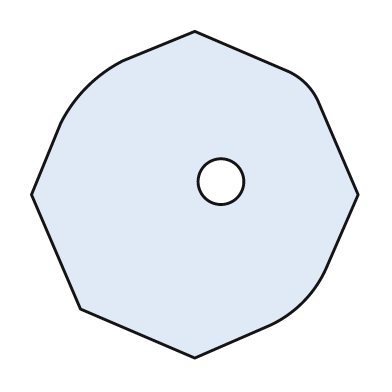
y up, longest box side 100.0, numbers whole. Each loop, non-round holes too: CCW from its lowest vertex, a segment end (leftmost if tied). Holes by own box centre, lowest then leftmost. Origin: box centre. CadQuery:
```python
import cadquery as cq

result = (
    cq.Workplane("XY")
    .moveTo(0.0, -50.0)
    .lineTo(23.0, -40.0)
    .threePointArc((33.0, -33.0), (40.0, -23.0))
    .lineTo(50.0, 0.0)
    .lineTo(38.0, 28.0)
    .threePointArc((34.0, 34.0), (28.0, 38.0))
    .lineTo(0.0, 50.0)
    .lineTo(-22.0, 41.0)
    .threePointArc((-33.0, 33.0), (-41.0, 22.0))
    .lineTo(-50.0, 0.0)
    .lineTo(-35.0, -35.0)
    .close()
    .moveTo(8.0, 4.0)
    .circle(7.0)
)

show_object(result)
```